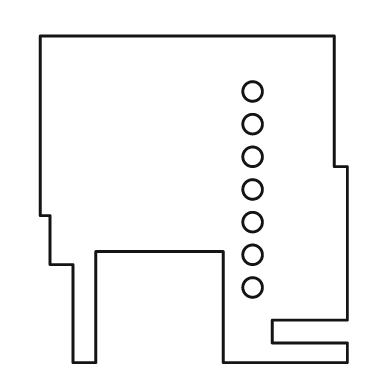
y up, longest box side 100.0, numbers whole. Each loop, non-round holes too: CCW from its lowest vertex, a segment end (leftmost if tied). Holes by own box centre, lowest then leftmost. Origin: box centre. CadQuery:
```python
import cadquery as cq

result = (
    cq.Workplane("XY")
    .moveTo(-37.0, -50.0)
    .lineTo(-30.0, -50.0)
    .lineTo(-30.0, -16.0)
    .lineTo(9.0, -16.0)
    .lineTo(9.0, -50.0)
    .lineTo(47.0, -50.0)
    .lineTo(47.0, -44.0)
    .lineTo(24.0, -44.0)
    .lineTo(24.0, -37.0)
    .lineTo(47.0, -37.0)
    .lineTo(47.0, 10.0)
    .lineTo(43.0, 10.0)
    .lineTo(43.0, 50.0)
    .lineTo(-47.0, 50.0)
    .lineTo(-47.0, -5.0)
    .lineTo(-44.0, -5.0)
    .lineTo(-44.0, -20.0)
    .lineTo(-37.0, -20.0)
    .close()
    .moveTo(18.0, -27.0)
    .circle(3.0)
    .moveTo(18.0, -17.0)
    .circle(3.0)
    .moveTo(18.0, -7.0)
    .circle(3.0)
    .moveTo(18.0, 3.0)
    .circle(3.0)
    .moveTo(18.0, 13.0)
    .circle(3.0)
    .moveTo(18.0, 23.0)
    .circle(3.0)
    .moveTo(18.0, 33.0)
    .circle(3.0)
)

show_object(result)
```